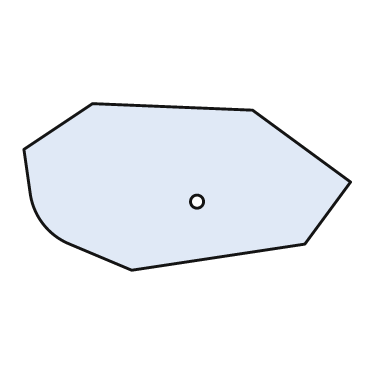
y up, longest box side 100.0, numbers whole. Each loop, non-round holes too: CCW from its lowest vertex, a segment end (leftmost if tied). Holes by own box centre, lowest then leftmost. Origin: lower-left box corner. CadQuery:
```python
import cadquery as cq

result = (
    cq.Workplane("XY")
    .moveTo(33.0, 0.0)
    .lineTo(86.0, 8.0)
    .lineTo(100.0, 27.0)
    .lineTo(70.0, 49.0)
    .lineTo(21.0, 51.0)
    .lineTo(0.0, 37.0)
    .lineTo(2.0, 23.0)
    .threePointArc((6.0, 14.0), (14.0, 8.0))
    .close()
    .moveTo(53.0, 21.0)
    .circle(2.0)
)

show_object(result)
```